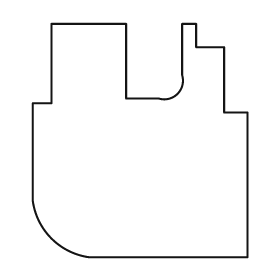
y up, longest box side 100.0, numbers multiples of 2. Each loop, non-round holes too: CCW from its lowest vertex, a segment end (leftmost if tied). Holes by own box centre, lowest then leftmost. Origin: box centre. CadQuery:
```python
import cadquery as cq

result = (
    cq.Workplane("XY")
    .moveTo(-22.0, -50.0)
    .lineTo(46.0, -50.0)
    .lineTo(46.0, 12.0)
    .lineTo(36.0, 12.0)
    .lineTo(36.0, 40.0)
    .lineTo(24.0, 40.0)
    .lineTo(24.0, 50.0)
    .lineTo(18.0, 50.0)
    .lineTo(18.0, 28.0)
    .threePointArc((16.0, 20.0), (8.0, 18.0))
    .lineTo(-6.0, 18.0)
    .lineTo(-6.0, 50.0)
    .lineTo(-38.0, 50.0)
    .lineTo(-38.0, 16.0)
    .lineTo(-46.0, 16.0)
    .lineTo(-46.0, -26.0)
    .threePointArc((-38.0, -42.0), (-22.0, -50.0))
    .close()
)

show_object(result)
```